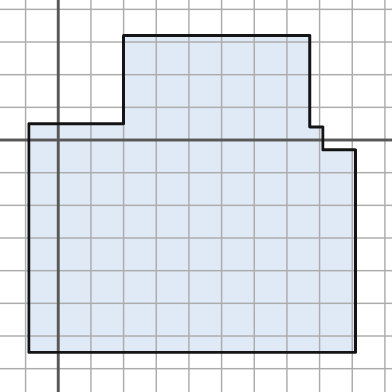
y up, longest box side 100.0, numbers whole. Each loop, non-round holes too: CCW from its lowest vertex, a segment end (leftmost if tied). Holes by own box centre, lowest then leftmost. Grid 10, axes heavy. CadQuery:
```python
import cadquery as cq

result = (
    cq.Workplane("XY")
    .moveTo(-9.0, -65.0)
    .lineTo(91.0, -65.0)
    .lineTo(91.0, -3.0)
    .lineTo(81.0, -3.0)
    .lineTo(81.0, 4.0)
    .lineTo(77.0, 4.0)
    .lineTo(77.0, 32.0)
    .lineTo(20.0, 32.0)
    .lineTo(20.0, 5.0)
    .lineTo(-9.0, 5.0)
    .close()
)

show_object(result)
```